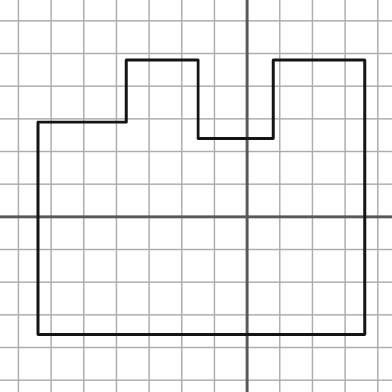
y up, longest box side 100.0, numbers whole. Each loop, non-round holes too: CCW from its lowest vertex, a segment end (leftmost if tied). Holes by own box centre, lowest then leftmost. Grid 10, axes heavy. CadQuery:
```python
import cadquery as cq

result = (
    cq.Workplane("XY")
    .moveTo(-64.0, -36.0)
    .lineTo(36.0, -36.0)
    .lineTo(36.0, 48.0)
    .lineTo(8.0, 48.0)
    .lineTo(8.0, 24.0)
    .lineTo(-15.0, 24.0)
    .lineTo(-15.0, 48.0)
    .lineTo(-37.0, 48.0)
    .lineTo(-37.0, 29.0)
    .lineTo(-64.0, 29.0)
    .close()
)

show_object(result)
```